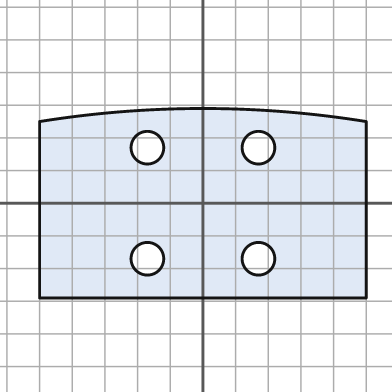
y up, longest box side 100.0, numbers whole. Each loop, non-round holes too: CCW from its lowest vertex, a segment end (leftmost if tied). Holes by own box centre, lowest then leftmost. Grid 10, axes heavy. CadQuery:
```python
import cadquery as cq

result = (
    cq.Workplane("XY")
    .moveTo(-50.0, -29.0)
    .lineTo(50.0, -29.0)
    .lineTo(50.0, 25.0)
    .threePointArc((0.0, 29.0), (-50.0, 25.0))
    .close()
    .moveTo(-17.0, -17.0)
    .circle(5.0)
    .moveTo(17.0, -17.0)
    .circle(5.0)
    .moveTo(-17.0, 17.0)
    .circle(5.0)
    .moveTo(17.0, 17.0)
    .circle(5.0)
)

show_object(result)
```